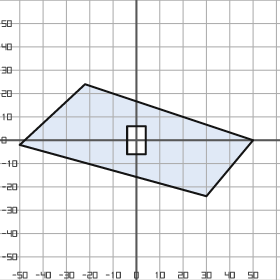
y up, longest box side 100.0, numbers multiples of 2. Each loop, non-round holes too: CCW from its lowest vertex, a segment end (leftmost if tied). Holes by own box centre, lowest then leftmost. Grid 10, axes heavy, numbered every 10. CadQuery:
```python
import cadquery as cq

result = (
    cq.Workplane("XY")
    .moveTo(30.0, -24.0)
    .lineTo(50.0, 0.0)
    .lineTo(-22.0, 24.0)
    .lineTo(-50.0, -2.0)
    .close()
    .moveTo(-4.0, -6.0)
    .lineTo(4.0, -6.0)
    .lineTo(4.0, 6.0)
    .lineTo(-4.0, 6.0)
    .close()
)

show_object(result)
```